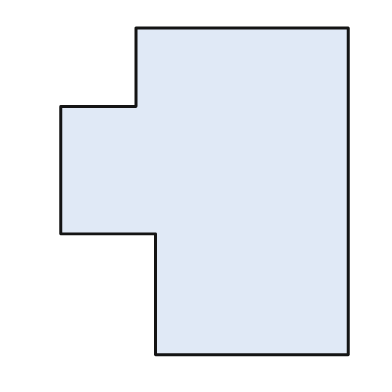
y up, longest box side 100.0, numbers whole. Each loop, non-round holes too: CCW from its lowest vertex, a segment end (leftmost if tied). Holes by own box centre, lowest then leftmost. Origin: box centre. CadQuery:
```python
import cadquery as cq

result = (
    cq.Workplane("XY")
    .moveTo(-15.0, -50.0)
    .lineTo(44.0, -50.0)
    .lineTo(44.0, 50.0)
    .lineTo(-21.0, 50.0)
    .lineTo(-21.0, 26.0)
    .lineTo(-44.0, 26.0)
    .lineTo(-44.0, -13.0)
    .lineTo(-15.0, -13.0)
    .close()
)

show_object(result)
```